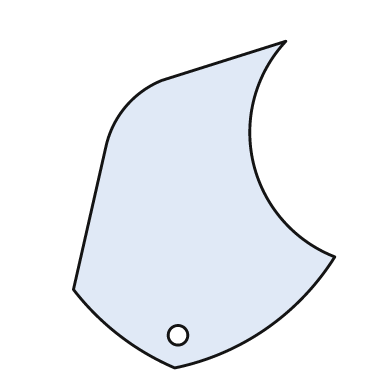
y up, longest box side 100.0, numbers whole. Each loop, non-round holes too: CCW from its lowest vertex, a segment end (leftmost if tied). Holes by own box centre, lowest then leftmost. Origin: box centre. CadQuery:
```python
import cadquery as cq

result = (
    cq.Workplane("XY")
    .moveTo(-9.0, -50.0)
    .threePointArc((19.0, -38.0), (40.0, -16.0))
    .threePointArc((15.0, 13.0), (25.0, 50.0))
    .lineTo(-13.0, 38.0)
    .threePointArc((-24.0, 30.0), (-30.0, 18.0))
    .lineTo(-40.0, -26.0)
    .threePointArc((-26.0, -40.0), (-9.0, -50.0))
    .close()
    .moveTo(-8.0, -40.0)
    .circle(3.0)
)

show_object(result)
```